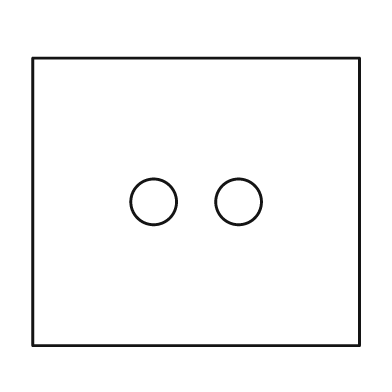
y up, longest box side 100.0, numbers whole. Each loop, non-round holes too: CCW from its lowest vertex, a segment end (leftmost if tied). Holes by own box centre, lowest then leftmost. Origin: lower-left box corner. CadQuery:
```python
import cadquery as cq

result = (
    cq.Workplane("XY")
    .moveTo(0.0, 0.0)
    .lineTo(100.0, 0.0)
    .lineTo(100.0, 88.0)
    .lineTo(0.0, 88.0)
    .close()
    .moveTo(37.0, 44.0)
    .circle(7.0)
    .moveTo(63.0, 44.0)
    .circle(7.0)
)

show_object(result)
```